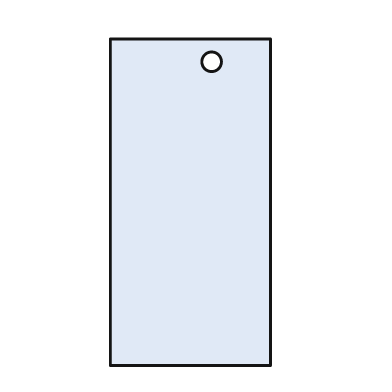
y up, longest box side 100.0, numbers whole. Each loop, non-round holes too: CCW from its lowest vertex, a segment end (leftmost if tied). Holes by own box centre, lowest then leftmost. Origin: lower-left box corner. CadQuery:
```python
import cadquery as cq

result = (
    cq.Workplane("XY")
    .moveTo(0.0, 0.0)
    .lineTo(49.0, 0.0)
    .lineTo(49.0, 100.0)
    .lineTo(0.0, 100.0)
    .close()
    .moveTo(31.0, 93.0)
    .circle(3.0)
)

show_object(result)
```